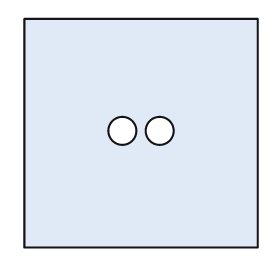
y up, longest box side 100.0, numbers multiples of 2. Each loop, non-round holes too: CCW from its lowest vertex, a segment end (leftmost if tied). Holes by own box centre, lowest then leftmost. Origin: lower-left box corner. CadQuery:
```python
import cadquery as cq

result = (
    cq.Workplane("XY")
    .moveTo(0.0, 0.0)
    .lineTo(100.0, 0.0)
    .lineTo(100.0, 98.0)
    .lineTo(0.0, 98.0)
    .close()
    .moveTo(42.0, 50.0)
    .circle(6.0)
    .moveTo(58.0, 50.0)
    .circle(6.0)
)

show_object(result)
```